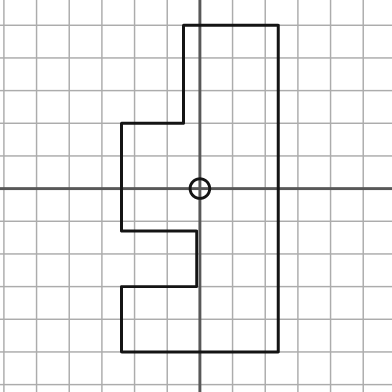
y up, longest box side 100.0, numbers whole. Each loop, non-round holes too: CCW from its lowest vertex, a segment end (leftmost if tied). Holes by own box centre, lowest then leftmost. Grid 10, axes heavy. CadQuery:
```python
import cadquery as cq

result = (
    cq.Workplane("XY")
    .moveTo(-24.0, -50.0)
    .lineTo(24.0, -50.0)
    .lineTo(24.0, 50.0)
    .lineTo(-5.0, 50.0)
    .lineTo(-5.0, 20.0)
    .lineTo(-24.0, 20.0)
    .lineTo(-24.0, -13.0)
    .lineTo(-1.0, -13.0)
    .lineTo(-1.0, -30.0)
    .lineTo(-24.0, -30.0)
    .close()
    .moveTo(0.0, 0.0)
    .circle(3.0)
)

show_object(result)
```